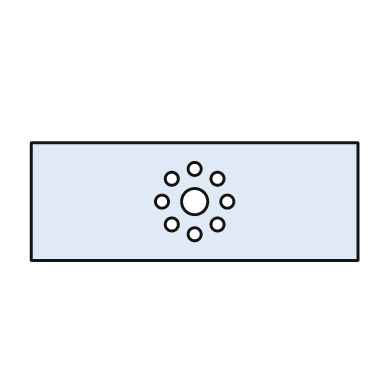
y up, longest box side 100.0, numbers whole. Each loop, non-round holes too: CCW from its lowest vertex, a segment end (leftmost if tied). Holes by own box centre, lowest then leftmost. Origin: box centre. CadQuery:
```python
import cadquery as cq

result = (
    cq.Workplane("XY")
    .moveTo(-50.0, -18.0)
    .lineTo(50.0, -18.0)
    .lineTo(50.0, 18.0)
    .lineTo(-50.0, 18.0)
    .close()
    .moveTo(0.0, -10.0)
    .circle(2.0)
    .moveTo(-7.0, -7.0)
    .circle(2.0)
    .moveTo(7.0, -7.0)
    .circle(2.0)
    .moveTo(-10.0, 0.0)
    .circle(2.0)
    .moveTo(0.0, 0.0)
    .circle(4.0)
    .moveTo(10.0, 0.0)
    .circle(2.0)
    .moveTo(-7.0, 7.0)
    .circle(2.0)
    .moveTo(7.0, 7.0)
    .circle(2.0)
    .moveTo(0.0, 10.0)
    .circle(2.0)
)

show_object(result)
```